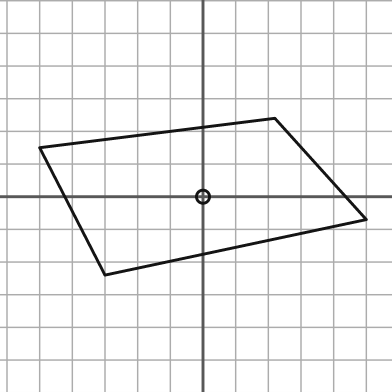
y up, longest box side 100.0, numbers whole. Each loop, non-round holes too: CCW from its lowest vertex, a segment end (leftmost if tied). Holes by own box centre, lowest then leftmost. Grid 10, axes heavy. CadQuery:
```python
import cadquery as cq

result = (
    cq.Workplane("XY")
    .moveTo(-30.0, -24.0)
    .lineTo(50.0, -7.0)
    .lineTo(22.0, 24.0)
    .lineTo(-50.0, 15.0)
    .close()
    .moveTo(0.0, 0.0)
    .circle(2.0)
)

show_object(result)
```